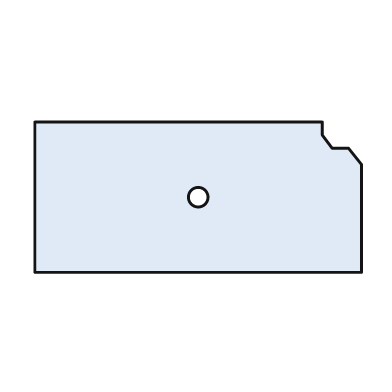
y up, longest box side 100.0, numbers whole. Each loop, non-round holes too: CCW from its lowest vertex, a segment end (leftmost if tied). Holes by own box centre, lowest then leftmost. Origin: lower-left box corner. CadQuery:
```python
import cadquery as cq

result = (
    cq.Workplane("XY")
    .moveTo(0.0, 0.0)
    .lineTo(100.0, 0.0)
    .lineTo(100.0, 33.0)
    .lineTo(96.0, 38.0)
    .lineTo(91.0, 38.0)
    .lineTo(88.0, 42.0)
    .lineTo(88.0, 46.0)
    .lineTo(0.0, 46.0)
    .close()
    .moveTo(50.0, 23.0)
    .circle(3.0)
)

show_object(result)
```